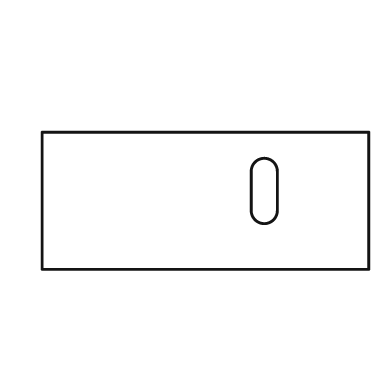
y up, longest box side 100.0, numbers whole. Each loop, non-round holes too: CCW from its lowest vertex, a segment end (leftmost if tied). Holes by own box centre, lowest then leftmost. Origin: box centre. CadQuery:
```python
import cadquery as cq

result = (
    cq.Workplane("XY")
    .moveTo(-50.0, -21.0)
    .lineTo(50.0, -21.0)
    .lineTo(50.0, 21.0)
    .lineTo(-50.0, 21.0)
    .close()
    .moveTo(14.0, -3.0)
    .threePointArc((18.0, -7.0), (22.0, -3.0))
    .lineTo(22.0, 9.0)
    .threePointArc((18.0, 13.0), (14.0, 9.0))
    .close()
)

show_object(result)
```